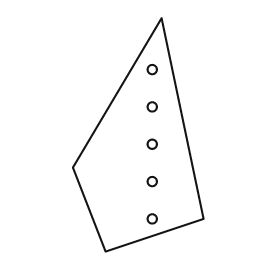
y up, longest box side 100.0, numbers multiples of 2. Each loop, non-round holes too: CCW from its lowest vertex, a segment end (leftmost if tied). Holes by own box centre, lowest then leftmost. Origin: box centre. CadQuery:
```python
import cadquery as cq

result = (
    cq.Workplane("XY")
    .moveTo(-14.0, -50.0)
    .lineTo(28.0, -36.0)
    .lineTo(10.0, 50.0)
    .lineTo(-28.0, -14.0)
    .close()
    .moveTo(6.0, -36.0)
    .circle(2.0)
    .moveTo(6.0, -20.0)
    .circle(2.0)
    .moveTo(6.0, -4.0)
    .circle(2.0)
    .moveTo(6.0, 12.0)
    .circle(2.0)
    .moveTo(6.0, 28.0)
    .circle(2.0)
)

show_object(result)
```